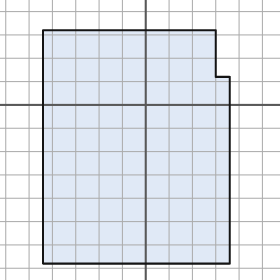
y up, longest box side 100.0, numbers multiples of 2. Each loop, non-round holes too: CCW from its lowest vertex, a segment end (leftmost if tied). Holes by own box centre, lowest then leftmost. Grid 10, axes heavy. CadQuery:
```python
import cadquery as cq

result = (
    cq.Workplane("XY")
    .moveTo(-44.0, -68.0)
    .lineTo(36.0, -68.0)
    .lineTo(36.0, 12.0)
    .lineTo(30.0, 12.0)
    .lineTo(30.0, 32.0)
    .lineTo(-44.0, 32.0)
    .close()
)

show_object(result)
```